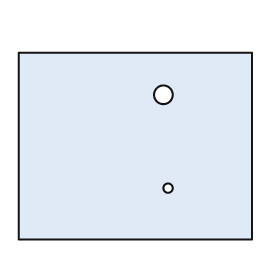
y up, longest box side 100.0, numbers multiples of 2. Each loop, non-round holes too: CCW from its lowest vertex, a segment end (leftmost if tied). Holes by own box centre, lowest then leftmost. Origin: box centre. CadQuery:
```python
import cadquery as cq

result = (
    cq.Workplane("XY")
    .moveTo(-50.0, -40.0)
    .lineTo(50.0, -40.0)
    .lineTo(50.0, 40.0)
    .lineTo(-50.0, 40.0)
    .close()
    .moveTo(14.0, -18.0)
    .circle(2.0)
    .moveTo(12.0, 22.0)
    .circle(4.0)
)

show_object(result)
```